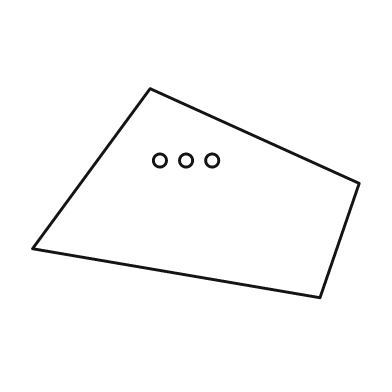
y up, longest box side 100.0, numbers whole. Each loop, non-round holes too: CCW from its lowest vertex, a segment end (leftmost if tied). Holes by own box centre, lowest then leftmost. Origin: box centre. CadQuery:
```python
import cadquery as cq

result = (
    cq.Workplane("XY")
    .moveTo(38.0, -32.0)
    .lineTo(50.0, 3.0)
    .lineTo(-14.0, 32.0)
    .lineTo(-50.0, -17.0)
    .close()
    .moveTo(-11.0, 10.0)
    .circle(2.0)
    .moveTo(-3.0, 10.0)
    .circle(2.0)
    .moveTo(5.0, 10.0)
    .circle(2.0)
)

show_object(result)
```